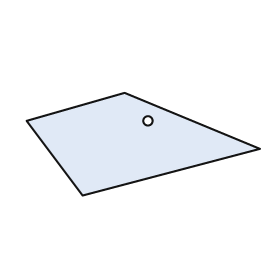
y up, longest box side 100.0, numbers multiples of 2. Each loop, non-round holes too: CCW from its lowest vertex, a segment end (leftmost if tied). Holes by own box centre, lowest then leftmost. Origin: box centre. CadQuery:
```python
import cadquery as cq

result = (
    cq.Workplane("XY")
    .moveTo(-26.0, -22.0)
    .lineTo(50.0, -2.0)
    .lineTo(-8.0, 22.0)
    .lineTo(-50.0, 10.0)
    .close()
    .moveTo(2.0, 10.0)
    .circle(2.0)
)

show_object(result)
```